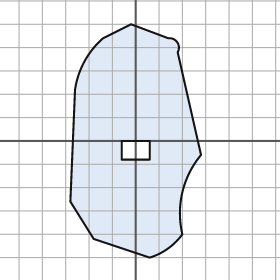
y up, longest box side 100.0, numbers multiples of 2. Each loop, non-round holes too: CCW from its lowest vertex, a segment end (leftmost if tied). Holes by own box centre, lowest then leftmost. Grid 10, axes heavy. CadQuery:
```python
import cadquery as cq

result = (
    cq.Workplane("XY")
    .moveTo(6.0, -50.0)
    .threePointArc((14.0, -46.0), (20.0, -40.0))
    .threePointArc((20.0, -22.0), (28.0, -6.0))
    .lineTo(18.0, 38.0)
    .threePointArc((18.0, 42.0), (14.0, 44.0))
    .lineTo(-2.0, 50.0)
    .lineTo(-14.0, 44.0)
    .threePointArc((-22.0, 34.0), (-26.0, 22.0))
    .lineTo(-28.0, -26.0)
    .lineTo(-18.0, -42.0)
    .close()
    .moveTo(-6.0, -8.0)
    .lineTo(6.0, -8.0)
    .lineTo(6.0, 0.0)
    .lineTo(-6.0, 0.0)
    .close()
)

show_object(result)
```